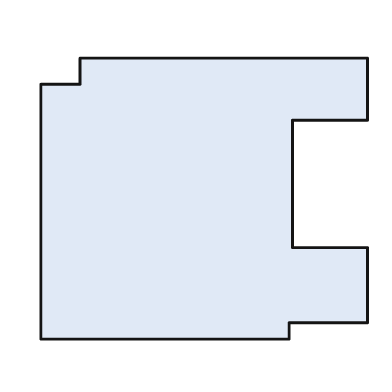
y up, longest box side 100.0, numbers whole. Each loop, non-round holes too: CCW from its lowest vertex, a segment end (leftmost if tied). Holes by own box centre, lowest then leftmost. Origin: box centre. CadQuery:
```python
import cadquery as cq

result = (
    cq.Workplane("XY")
    .moveTo(-50.0, -43.0)
    .lineTo(26.0, -43.0)
    .lineTo(26.0, -38.0)
    .lineTo(50.0, -38.0)
    .lineTo(50.0, -15.0)
    .lineTo(27.0, -15.0)
    .lineTo(27.0, 24.0)
    .lineTo(50.0, 24.0)
    .lineTo(50.0, 43.0)
    .lineTo(-38.0, 43.0)
    .lineTo(-38.0, 35.0)
    .lineTo(-50.0, 35.0)
    .close()
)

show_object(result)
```